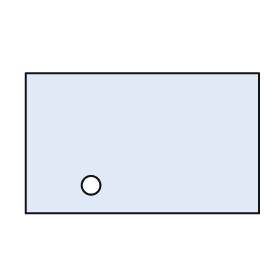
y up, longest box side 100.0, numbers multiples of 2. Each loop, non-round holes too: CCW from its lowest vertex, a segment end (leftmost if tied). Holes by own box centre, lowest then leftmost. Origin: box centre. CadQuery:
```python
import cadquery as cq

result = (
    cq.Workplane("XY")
    .moveTo(-50.0, -30.0)
    .lineTo(50.0, -30.0)
    .lineTo(50.0, 30.0)
    .lineTo(-50.0, 30.0)
    .close()
    .moveTo(-22.0, -18.0)
    .circle(4.0)
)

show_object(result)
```